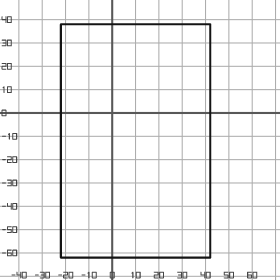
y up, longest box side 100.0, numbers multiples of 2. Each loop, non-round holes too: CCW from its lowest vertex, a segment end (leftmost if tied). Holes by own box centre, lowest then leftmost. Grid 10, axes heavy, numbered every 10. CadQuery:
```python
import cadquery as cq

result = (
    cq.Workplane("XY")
    .moveTo(-22.0, -62.0)
    .lineTo(42.0, -62.0)
    .lineTo(42.0, 38.0)
    .lineTo(-22.0, 38.0)
    .close()
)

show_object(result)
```